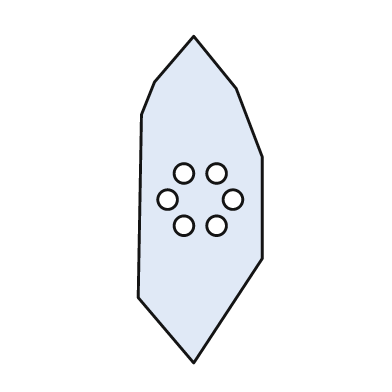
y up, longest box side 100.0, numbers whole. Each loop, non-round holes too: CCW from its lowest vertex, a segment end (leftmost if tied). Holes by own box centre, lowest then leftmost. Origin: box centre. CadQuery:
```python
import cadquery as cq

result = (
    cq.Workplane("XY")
    .moveTo(-2.0, -50.0)
    .lineTo(19.0, -18.0)
    .lineTo(19.0, 13.0)
    .lineTo(11.0, 34.0)
    .lineTo(-2.0, 50.0)
    .lineTo(-14.0, 36.0)
    .lineTo(-18.0, 26.0)
    .lineTo(-19.0, -30.0)
    .close()
    .moveTo(-5.0, -8.0)
    .circle(3.0)
    .moveTo(5.0, -8.0)
    .circle(3.0)
    .moveTo(-10.0, 0.0)
    .circle(3.0)
    .moveTo(10.0, 0.0)
    .circle(3.0)
    .moveTo(-5.0, 8.0)
    .circle(3.0)
    .moveTo(5.0, 8.0)
    .circle(3.0)
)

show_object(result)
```